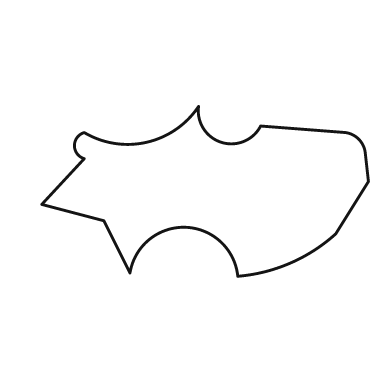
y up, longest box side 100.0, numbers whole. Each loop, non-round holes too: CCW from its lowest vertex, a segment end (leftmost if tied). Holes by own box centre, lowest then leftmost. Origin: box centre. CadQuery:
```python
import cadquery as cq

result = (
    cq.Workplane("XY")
    .moveTo(10.0, -26.0)
    .threePointArc((26.0, -22.0), (40.0, -13.0))
    .lineTo(50.0, 3.0)
    .lineTo(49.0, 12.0)
    .threePointArc((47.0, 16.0), (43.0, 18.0))
    .lineTo(17.0, 20.0)
    .threePointArc((5.0, 15.0), (-2.0, 26.0))
    .threePointArc((-18.0, 15.0), (-37.0, 18.0))
    .threePointArc((-40.0, 14.0), (-37.0, 10.0))
    .lineTo(-50.0, -4.0)
    .lineTo(-31.0, -9.0)
    .lineTo(-23.0, -25.0)
    .threePointArc((-6.0, -11.0), (10.0, -26.0))
    .close()
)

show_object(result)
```